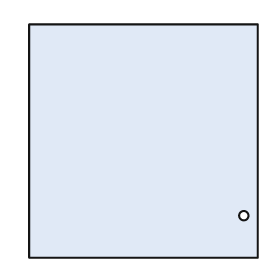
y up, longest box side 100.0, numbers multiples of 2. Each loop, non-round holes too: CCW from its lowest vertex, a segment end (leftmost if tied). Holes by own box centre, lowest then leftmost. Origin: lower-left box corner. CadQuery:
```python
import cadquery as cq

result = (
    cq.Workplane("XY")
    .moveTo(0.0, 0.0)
    .lineTo(98.0, 0.0)
    .lineTo(98.0, 100.0)
    .lineTo(0.0, 100.0)
    .close()
    .moveTo(92.0, 18.0)
    .circle(2.0)
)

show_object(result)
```